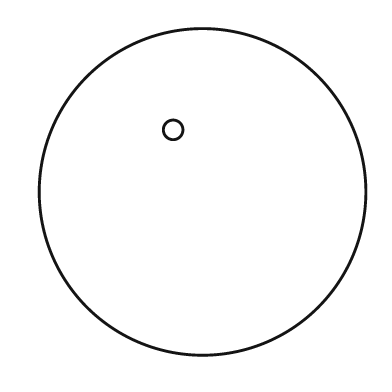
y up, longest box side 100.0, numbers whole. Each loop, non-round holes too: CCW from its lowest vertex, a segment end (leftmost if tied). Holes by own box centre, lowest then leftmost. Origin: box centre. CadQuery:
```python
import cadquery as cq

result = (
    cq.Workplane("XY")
    .moveTo(0.0, 0.0)
    .circle(50.0)
    .moveTo(-9.0, 19.0)
    .circle(3.0)
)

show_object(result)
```